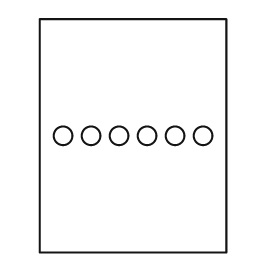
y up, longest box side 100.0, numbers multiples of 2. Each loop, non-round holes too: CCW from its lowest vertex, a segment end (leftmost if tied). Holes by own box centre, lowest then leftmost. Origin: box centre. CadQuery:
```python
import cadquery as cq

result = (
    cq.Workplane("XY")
    .moveTo(-40.0, -50.0)
    .lineTo(40.0, -50.0)
    .lineTo(40.0, 50.0)
    .lineTo(-40.0, 50.0)
    .close()
    .moveTo(-30.0, 0.0)
    .circle(4.0)
    .moveTo(-18.0, 0.0)
    .circle(4.0)
    .moveTo(-6.0, 0.0)
    .circle(4.0)
    .moveTo(6.0, 0.0)
    .circle(4.0)
    .moveTo(18.0, 0.0)
    .circle(4.0)
    .moveTo(30.0, 0.0)
    .circle(4.0)
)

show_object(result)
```